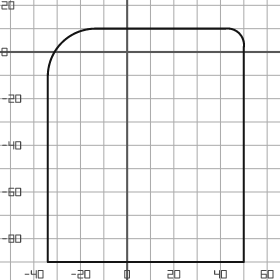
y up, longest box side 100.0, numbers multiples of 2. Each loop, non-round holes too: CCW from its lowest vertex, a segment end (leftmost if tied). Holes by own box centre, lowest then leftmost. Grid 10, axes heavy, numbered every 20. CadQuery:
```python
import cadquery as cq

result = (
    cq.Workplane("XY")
    .moveTo(-34.0, -90.0)
    .lineTo(50.0, -90.0)
    .lineTo(50.0, 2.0)
    .threePointArc((48.0, 8.0), (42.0, 10.0))
    .lineTo(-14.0, 10.0)
    .threePointArc((-28.0, 4.0), (-34.0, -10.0))
    .close()
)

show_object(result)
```